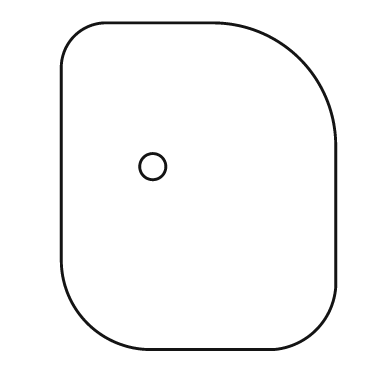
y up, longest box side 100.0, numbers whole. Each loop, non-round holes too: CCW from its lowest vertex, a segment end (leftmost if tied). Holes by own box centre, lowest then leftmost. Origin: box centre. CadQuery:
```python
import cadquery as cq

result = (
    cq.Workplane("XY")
    .moveTo(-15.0, -50.0)
    .lineTo(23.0, -50.0)
    .threePointArc((36.0, -44.0), (42.0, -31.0))
    .lineTo(42.0, 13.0)
    .threePointArc((31.0, 39.0), (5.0, 50.0))
    .lineTo(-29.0, 50.0)
    .threePointArc((-38.0, 46.0), (-42.0, 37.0))
    .lineTo(-42.0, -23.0)
    .threePointArc((-34.0, -42.0), (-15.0, -50.0))
    .close()
    .moveTo(-14.0, 6.0)
    .circle(4.0)
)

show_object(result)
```